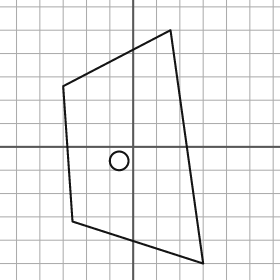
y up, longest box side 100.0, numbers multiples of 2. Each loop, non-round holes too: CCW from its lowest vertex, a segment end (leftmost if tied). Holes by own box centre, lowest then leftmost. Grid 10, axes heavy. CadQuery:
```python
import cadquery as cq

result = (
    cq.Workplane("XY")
    .moveTo(30.0, -50.0)
    .lineTo(16.0, 50.0)
    .lineTo(-30.0, 26.0)
    .lineTo(-26.0, -32.0)
    .close()
    .moveTo(-6.0, -6.0)
    .circle(4.0)
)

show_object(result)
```